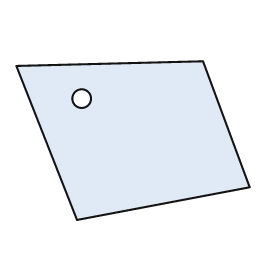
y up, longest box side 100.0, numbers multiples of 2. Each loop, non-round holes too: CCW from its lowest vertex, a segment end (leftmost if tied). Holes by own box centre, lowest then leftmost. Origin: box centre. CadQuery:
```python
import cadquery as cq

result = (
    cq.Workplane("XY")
    .moveTo(-24.0, -34.0)
    .lineTo(50.0, -20.0)
    .lineTo(30.0, 34.0)
    .lineTo(-50.0, 32.0)
    .close()
    .moveTo(-22.0, 18.0)
    .circle(4.0)
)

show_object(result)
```